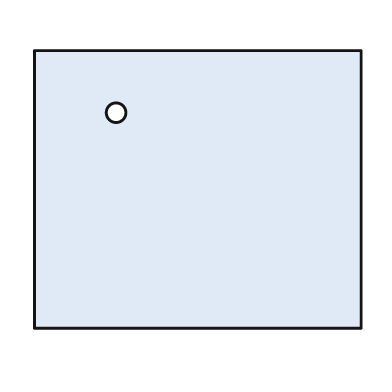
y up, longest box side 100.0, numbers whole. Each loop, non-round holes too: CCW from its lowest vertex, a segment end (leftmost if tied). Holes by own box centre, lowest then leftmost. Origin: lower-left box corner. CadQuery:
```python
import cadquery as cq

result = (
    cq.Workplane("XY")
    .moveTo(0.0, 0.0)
    .lineTo(100.0, 0.0)
    .lineTo(100.0, 85.0)
    .lineTo(0.0, 85.0)
    .close()
    .moveTo(25.0, 66.0)
    .circle(3.0)
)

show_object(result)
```